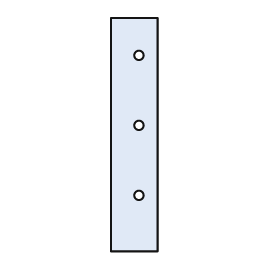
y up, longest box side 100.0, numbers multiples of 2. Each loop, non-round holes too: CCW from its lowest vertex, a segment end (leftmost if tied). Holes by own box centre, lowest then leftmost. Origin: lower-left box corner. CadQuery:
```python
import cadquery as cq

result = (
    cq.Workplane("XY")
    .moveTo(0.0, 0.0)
    .lineTo(20.0, 0.0)
    .lineTo(20.0, 100.0)
    .lineTo(0.0, 100.0)
    .close()
    .moveTo(12.0, 24.0)
    .circle(2.0)
    .moveTo(12.0, 54.0)
    .circle(2.0)
    .moveTo(12.0, 84.0)
    .circle(2.0)
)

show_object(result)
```